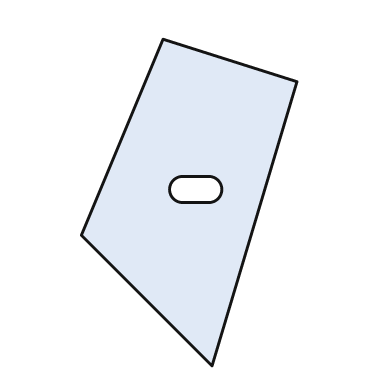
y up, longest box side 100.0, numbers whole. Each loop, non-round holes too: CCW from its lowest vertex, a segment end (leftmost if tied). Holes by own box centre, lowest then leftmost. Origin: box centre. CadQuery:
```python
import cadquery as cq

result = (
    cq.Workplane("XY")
    .moveTo(7.0, -50.0)
    .lineTo(33.0, 37.0)
    .lineTo(-8.0, 50.0)
    .lineTo(-33.0, -10.0)
    .close()
    .moveTo(-2.0, 0.0)
    .lineTo(6.0, 0.0)
    .threePointArc((10.0, 4.0), (6.0, 8.0))
    .lineTo(-2.0, 8.0)
    .threePointArc((-6.0, 4.0), (-2.0, 0.0))
    .close()
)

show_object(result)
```